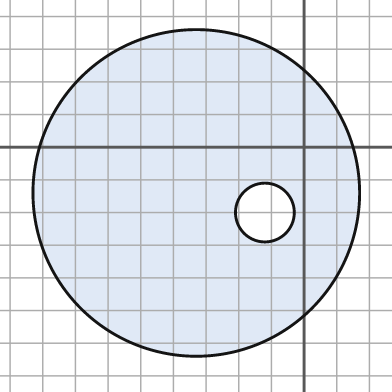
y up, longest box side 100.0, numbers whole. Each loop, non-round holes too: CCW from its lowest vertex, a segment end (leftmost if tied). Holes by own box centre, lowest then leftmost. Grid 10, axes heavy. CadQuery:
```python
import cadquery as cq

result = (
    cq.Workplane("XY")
    .moveTo(-33.0, -14.0)
    .circle(50.0)
    .moveTo(-12.0, -20.0)
    .circle(9.0)
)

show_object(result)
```